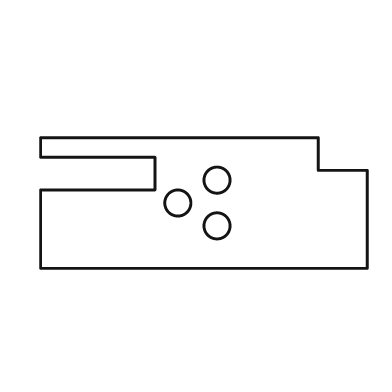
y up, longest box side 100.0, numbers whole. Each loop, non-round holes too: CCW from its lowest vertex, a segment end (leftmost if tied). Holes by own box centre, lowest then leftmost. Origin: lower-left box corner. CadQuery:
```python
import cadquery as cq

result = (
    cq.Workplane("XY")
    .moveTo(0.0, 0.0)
    .lineTo(100.0, 0.0)
    .lineTo(100.0, 30.0)
    .lineTo(85.0, 30.0)
    .lineTo(85.0, 40.0)
    .lineTo(0.0, 40.0)
    .lineTo(0.0, 34.0)
    .lineTo(35.0, 34.0)
    .lineTo(35.0, 24.0)
    .lineTo(0.0, 24.0)
    .close()
    .moveTo(54.0, 13.0)
    .circle(4.0)
    .moveTo(42.0, 20.0)
    .circle(4.0)
    .moveTo(54.0, 27.0)
    .circle(4.0)
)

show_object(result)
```